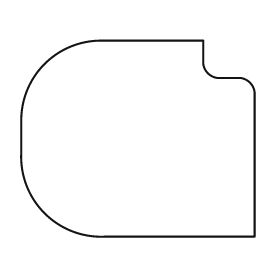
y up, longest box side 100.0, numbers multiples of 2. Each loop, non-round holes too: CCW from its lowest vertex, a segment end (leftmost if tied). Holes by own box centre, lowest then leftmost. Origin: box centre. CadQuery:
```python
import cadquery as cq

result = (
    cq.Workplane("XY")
    .moveTo(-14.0, -42.0)
    .lineTo(50.0, -42.0)
    .lineTo(50.0, 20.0)
    .threePointArc((48.0, 24.0), (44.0, 26.0))
    .lineTo(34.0, 26.0)
    .threePointArc((30.0, 28.0), (28.0, 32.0))
    .lineTo(28.0, 42.0)
    .lineTo(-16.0, 42.0)
    .threePointArc((-40.0, 32.0), (-50.0, 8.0))
    .lineTo(-50.0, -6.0)
    .threePointArc((-40.0, -32.0), (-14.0, -42.0))
    .close()
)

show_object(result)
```